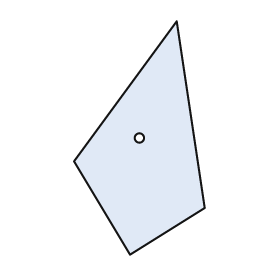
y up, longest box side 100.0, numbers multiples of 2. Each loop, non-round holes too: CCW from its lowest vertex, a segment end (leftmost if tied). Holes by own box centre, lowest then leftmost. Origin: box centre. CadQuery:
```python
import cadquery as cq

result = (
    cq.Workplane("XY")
    .moveTo(-4.0, -50.0)
    .lineTo(28.0, -30.0)
    .lineTo(16.0, 50.0)
    .lineTo(-28.0, -10.0)
    .close()
    .moveTo(0.0, 0.0)
    .circle(2.0)
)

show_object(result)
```